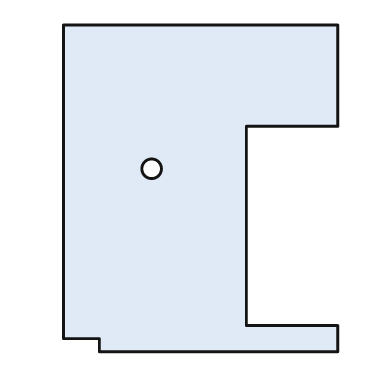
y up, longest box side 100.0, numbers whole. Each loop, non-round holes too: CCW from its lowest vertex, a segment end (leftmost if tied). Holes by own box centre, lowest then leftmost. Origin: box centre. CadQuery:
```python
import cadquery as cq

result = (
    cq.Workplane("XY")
    .moveTo(-31.0, -50.0)
    .lineTo(42.0, -50.0)
    .lineTo(42.0, -42.0)
    .lineTo(14.0, -42.0)
    .lineTo(14.0, 19.0)
    .lineTo(42.0, 19.0)
    .lineTo(42.0, 50.0)
    .lineTo(-42.0, 50.0)
    .lineTo(-42.0, -46.0)
    .lineTo(-31.0, -46.0)
    .close()
    .moveTo(-15.0, 6.0)
    .circle(3.0)
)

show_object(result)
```